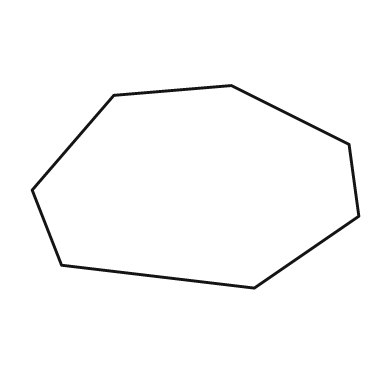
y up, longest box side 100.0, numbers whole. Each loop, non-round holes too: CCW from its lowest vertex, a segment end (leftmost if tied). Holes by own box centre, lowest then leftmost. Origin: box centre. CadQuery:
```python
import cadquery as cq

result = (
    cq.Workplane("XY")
    .moveTo(18.0, -31.0)
    .lineTo(50.0, -9.0)
    .lineTo(47.0, 13.0)
    .lineTo(11.0, 31.0)
    .lineTo(-25.0, 28.0)
    .lineTo(-50.0, -1.0)
    .lineTo(-41.0, -24.0)
    .close()
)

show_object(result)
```